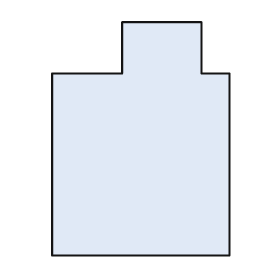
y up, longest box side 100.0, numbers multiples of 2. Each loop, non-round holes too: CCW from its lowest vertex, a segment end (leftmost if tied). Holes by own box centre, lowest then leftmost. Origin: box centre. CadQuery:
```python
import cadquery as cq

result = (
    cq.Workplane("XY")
    .moveTo(-38.0, -50.0)
    .lineTo(38.0, -50.0)
    .lineTo(38.0, 28.0)
    .lineTo(26.0, 28.0)
    .lineTo(26.0, 50.0)
    .lineTo(-8.0, 50.0)
    .lineTo(-8.0, 28.0)
    .lineTo(-38.0, 28.0)
    .close()
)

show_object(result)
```